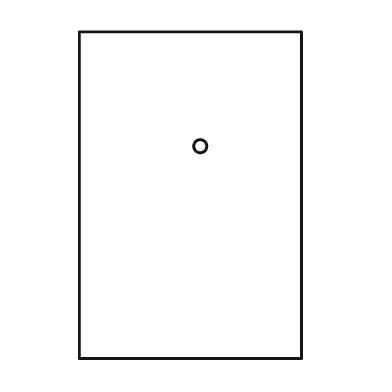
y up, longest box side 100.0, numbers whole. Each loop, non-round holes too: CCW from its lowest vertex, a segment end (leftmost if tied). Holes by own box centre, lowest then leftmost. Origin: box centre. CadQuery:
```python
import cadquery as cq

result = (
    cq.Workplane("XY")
    .moveTo(-34.0, -50.0)
    .lineTo(34.0, -50.0)
    .lineTo(34.0, 50.0)
    .lineTo(-34.0, 50.0)
    .close()
    .moveTo(3.0, 15.0)
    .circle(2.0)
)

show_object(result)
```